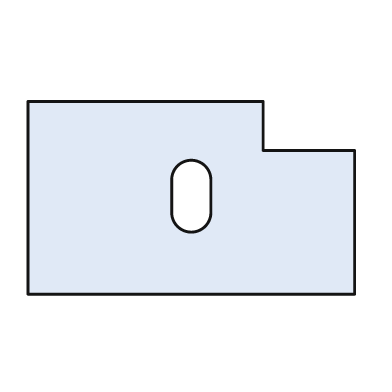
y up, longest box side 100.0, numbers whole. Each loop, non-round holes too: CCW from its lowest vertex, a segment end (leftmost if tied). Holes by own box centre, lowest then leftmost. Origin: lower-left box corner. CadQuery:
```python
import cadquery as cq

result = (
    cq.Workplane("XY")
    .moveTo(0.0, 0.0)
    .lineTo(100.0, 0.0)
    .lineTo(100.0, 44.0)
    .lineTo(72.0, 44.0)
    .lineTo(72.0, 59.0)
    .lineTo(0.0, 59.0)
    .close()
    .moveTo(44.0, 25.0)
    .threePointArc((50.0, 19.0), (56.0, 25.0))
    .lineTo(56.0, 35.0)
    .threePointArc((50.0, 41.0), (44.0, 35.0))
    .close()
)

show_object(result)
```